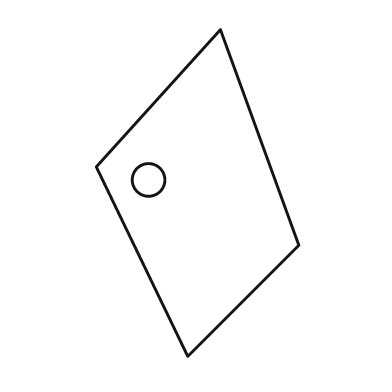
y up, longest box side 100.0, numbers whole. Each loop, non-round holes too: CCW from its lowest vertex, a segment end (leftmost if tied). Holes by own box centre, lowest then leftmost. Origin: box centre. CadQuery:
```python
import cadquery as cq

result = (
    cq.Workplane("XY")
    .moveTo(-3.0, -50.0)
    .lineTo(31.0, -16.0)
    .lineTo(7.0, 50.0)
    .lineTo(-31.0, 8.0)
    .close()
    .moveTo(-15.0, 4.0)
    .circle(5.0)
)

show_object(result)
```